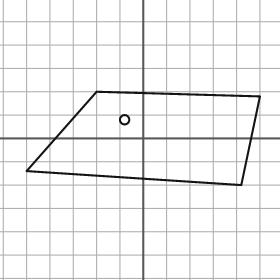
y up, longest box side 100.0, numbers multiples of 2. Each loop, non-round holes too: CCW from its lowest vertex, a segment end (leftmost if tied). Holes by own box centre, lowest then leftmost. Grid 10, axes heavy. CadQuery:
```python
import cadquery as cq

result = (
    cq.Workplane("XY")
    .moveTo(42.0, -20.0)
    .lineTo(50.0, 18.0)
    .lineTo(-20.0, 20.0)
    .lineTo(-50.0, -14.0)
    .close()
    .moveTo(-8.0, 8.0)
    .circle(2.0)
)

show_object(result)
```